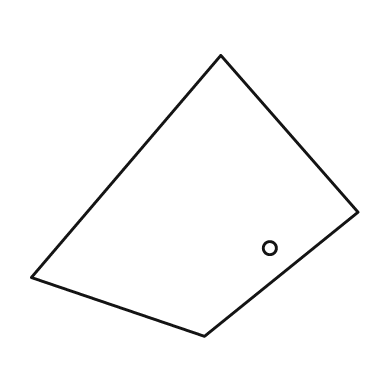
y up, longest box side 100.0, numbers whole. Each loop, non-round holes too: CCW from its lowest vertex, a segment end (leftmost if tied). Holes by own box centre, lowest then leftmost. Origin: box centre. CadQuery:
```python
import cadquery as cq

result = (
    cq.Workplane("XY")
    .moveTo(3.0, -43.0)
    .lineTo(50.0, -5.0)
    .lineTo(8.0, 43.0)
    .lineTo(-50.0, -25.0)
    .close()
    .moveTo(23.0, -16.0)
    .circle(2.0)
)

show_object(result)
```